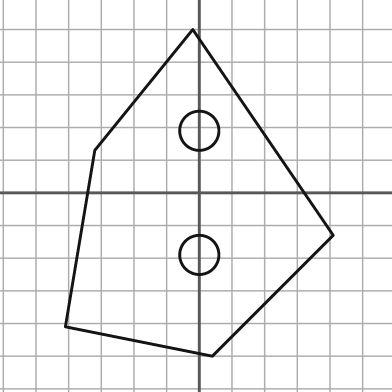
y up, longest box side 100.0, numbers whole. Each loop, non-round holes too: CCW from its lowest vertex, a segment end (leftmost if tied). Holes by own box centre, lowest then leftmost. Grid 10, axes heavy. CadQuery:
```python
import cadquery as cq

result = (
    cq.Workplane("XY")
    .moveTo(4.0, -50.0)
    .lineTo(41.0, -13.0)
    .lineTo(-2.0, 50.0)
    .lineTo(-32.0, 13.0)
    .lineTo(-41.0, -41.0)
    .close()
    .moveTo(0.0, -19.0)
    .circle(6.0)
    .moveTo(0.0, 19.0)
    .circle(6.0)
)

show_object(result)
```